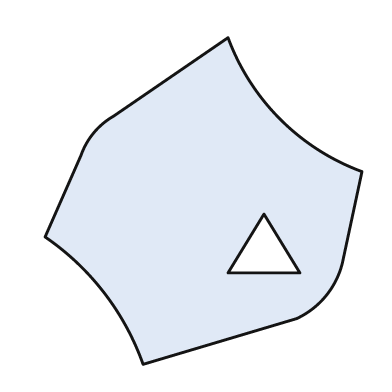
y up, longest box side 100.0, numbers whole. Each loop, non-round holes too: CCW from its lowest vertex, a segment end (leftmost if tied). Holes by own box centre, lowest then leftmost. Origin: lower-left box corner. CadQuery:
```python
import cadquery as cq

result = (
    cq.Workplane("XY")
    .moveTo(30.0, 0.0)
    .lineTo(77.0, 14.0)
    .threePointArc((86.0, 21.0), (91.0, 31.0))
    .lineTo(97.0, 59.0)
    .threePointArc((72.0, 75.0), (56.0, 100.0))
    .lineTo(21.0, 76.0)
    .threePointArc((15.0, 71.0), (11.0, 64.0))
    .lineTo(0.0, 39.0)
    .threePointArc((18.0, 22.0), (30.0, 0.0))
    .close()
    .moveTo(56.0, 28.0)
    .lineTo(78.0, 28.0)
    .lineTo(67.0, 46.0)
    .close()
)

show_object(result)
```